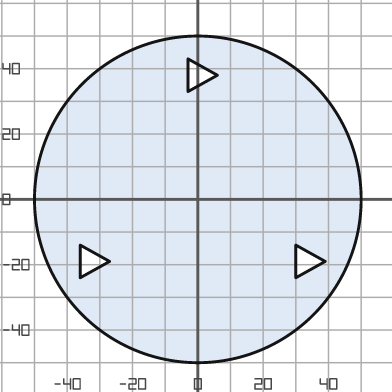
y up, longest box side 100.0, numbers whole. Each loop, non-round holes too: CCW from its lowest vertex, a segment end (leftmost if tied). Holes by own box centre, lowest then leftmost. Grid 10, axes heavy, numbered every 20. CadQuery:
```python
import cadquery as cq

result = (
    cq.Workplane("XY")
    .moveTo(0.0, 0.0)
    .circle(50.0)
    .moveTo(-36.0, -24.0)
    .lineTo(-27.0, -19.0)
    .lineTo(-36.0, -14.0)
    .close()
    .moveTo(30.0, -24.0)
    .lineTo(39.0, -19.0)
    .lineTo(30.0, -14.0)
    .close()
    .moveTo(-3.0, 33.0)
    .lineTo(6.0, 38.0)
    .lineTo(-3.0, 43.0)
    .close()
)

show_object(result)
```